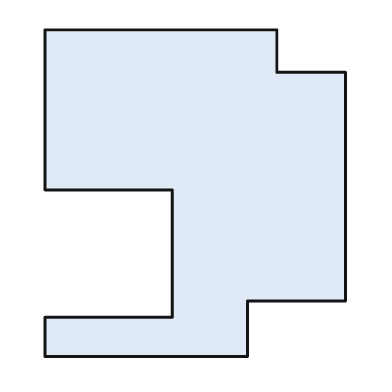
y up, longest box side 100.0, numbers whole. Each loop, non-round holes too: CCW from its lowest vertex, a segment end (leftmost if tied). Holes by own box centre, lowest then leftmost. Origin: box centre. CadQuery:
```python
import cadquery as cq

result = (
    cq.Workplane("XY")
    .moveTo(-46.0, -50.0)
    .lineTo(16.0, -50.0)
    .lineTo(16.0, -33.0)
    .lineTo(46.0, -33.0)
    .lineTo(46.0, 37.0)
    .lineTo(25.0, 37.0)
    .lineTo(25.0, 50.0)
    .lineTo(-46.0, 50.0)
    .lineTo(-46.0, 1.0)
    .lineTo(-7.0, 1.0)
    .lineTo(-7.0, -38.0)
    .lineTo(-46.0, -38.0)
    .close()
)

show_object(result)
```